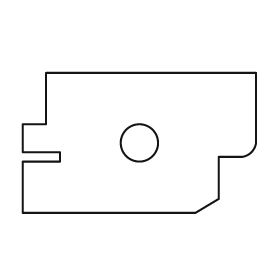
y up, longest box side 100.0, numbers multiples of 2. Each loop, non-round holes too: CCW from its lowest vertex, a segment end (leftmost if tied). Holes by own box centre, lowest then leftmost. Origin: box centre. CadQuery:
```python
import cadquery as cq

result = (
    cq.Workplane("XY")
    .moveTo(-50.0, -30.0)
    .lineTo(24.0, -30.0)
    .lineTo(34.0, -24.0)
    .lineTo(34.0, -6.0)
    .lineTo(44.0, -6.0)
    .threePointArc((48.0, -4.0), (50.0, 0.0))
    .lineTo(50.0, 30.0)
    .lineTo(-40.0, 30.0)
    .lineTo(-40.0, 8.0)
    .lineTo(-50.0, 8.0)
    .lineTo(-50.0, -4.0)
    .lineTo(-34.0, -4.0)
    .lineTo(-34.0, -8.0)
    .lineTo(-50.0, -8.0)
    .close()
    .moveTo(0.0, 0.0)
    .circle(8.0)
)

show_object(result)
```